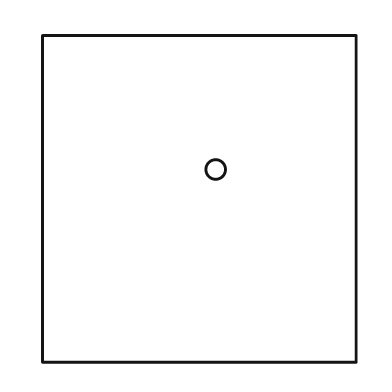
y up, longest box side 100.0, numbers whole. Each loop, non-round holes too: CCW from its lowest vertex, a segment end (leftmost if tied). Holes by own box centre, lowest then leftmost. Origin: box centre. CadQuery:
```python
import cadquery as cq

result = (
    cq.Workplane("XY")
    .moveTo(-48.0, -50.0)
    .lineTo(48.0, -50.0)
    .lineTo(48.0, 50.0)
    .lineTo(-48.0, 50.0)
    .close()
    .moveTo(5.0, 9.0)
    .circle(3.0)
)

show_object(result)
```